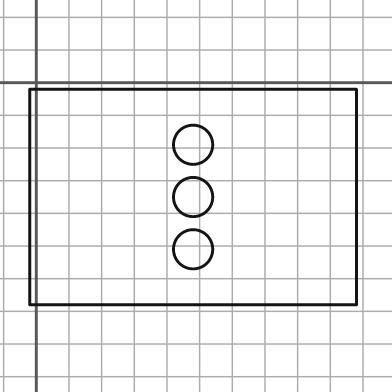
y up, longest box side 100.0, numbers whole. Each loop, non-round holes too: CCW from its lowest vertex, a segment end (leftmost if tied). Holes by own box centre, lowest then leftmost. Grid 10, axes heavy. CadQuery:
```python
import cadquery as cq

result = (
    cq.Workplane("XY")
    .moveTo(-2.0, -68.0)
    .lineTo(98.0, -68.0)
    .lineTo(98.0, -2.0)
    .lineTo(-2.0, -2.0)
    .close()
    .moveTo(48.0, -51.0)
    .circle(6.0)
    .moveTo(48.0, -35.0)
    .circle(6.0)
    .moveTo(48.0, -19.0)
    .circle(6.0)
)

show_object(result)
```